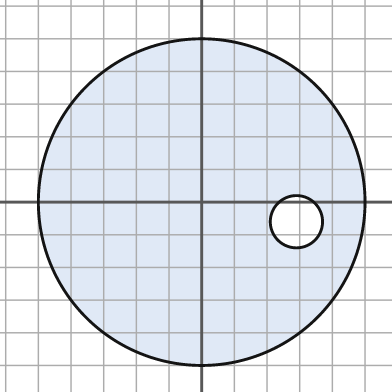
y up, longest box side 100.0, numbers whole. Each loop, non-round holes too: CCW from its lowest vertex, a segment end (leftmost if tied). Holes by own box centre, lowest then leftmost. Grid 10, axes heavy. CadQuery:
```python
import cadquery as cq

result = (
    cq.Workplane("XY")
    .moveTo(0.0, 0.0)
    .circle(50.0)
    .moveTo(29.0, -6.0)
    .circle(8.0)
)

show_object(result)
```